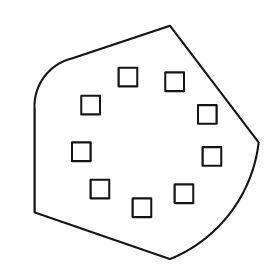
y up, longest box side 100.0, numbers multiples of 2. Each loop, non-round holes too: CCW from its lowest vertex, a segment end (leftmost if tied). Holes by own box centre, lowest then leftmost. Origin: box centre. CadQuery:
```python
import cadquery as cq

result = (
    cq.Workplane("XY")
    .moveTo(10.0, -50.0)
    .threePointArc((36.0, -30.0), (48.0, 0.0))
    .lineTo(10.0, 50.0)
    .lineTo(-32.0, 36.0)
    .threePointArc((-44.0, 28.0), (-48.0, 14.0))
    .lineTo(-48.0, -30.0)
    .close()
    .moveTo(-6.0, -32.0)
    .lineTo(2.0, -32.0)
    .lineTo(2.0, -24.0)
    .lineTo(-6.0, -24.0)
    .close()
    .moveTo(12.0, -26.0)
    .lineTo(20.0, -26.0)
    .lineTo(20.0, -18.0)
    .lineTo(12.0, -18.0)
    .close()
    .moveTo(-24.0, -24.0)
    .lineTo(-16.0, -24.0)
    .lineTo(-16.0, -16.0)
    .lineTo(-24.0, -16.0)
    .close()
    .moveTo(24.0, -10.0)
    .lineTo(32.0, -10.0)
    .lineTo(32.0, -2.0)
    .lineTo(24.0, -2.0)
    .close()
    .moveTo(-32.0, -8.0)
    .lineTo(-24.0, -8.0)
    .lineTo(-24.0, 0.0)
    .lineTo(-32.0, 0.0)
    .close()
    .moveTo(22.0, 8.0)
    .lineTo(30.0, 8.0)
    .lineTo(30.0, 16.0)
    .lineTo(22.0, 16.0)
    .close()
    .moveTo(-28.0, 12.0)
    .lineTo(-20.0, 12.0)
    .lineTo(-20.0, 20.0)
    .lineTo(-28.0, 20.0)
    .close()
    .moveTo(8.0, 22.0)
    .lineTo(16.0, 22.0)
    .lineTo(16.0, 30.0)
    .lineTo(8.0, 30.0)
    .close()
    .moveTo(-12.0, 24.0)
    .lineTo(-4.0, 24.0)
    .lineTo(-4.0, 32.0)
    .lineTo(-12.0, 32.0)
    .close()
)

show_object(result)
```